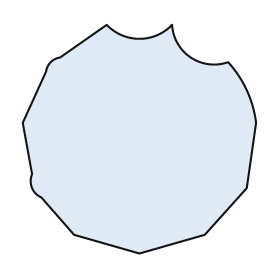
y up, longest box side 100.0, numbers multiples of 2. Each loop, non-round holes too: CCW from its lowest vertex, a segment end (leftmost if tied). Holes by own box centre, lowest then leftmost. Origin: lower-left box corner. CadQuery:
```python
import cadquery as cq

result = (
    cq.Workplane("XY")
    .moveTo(50.0, 0.0)
    .lineTo(78.0, 8.0)
    .lineTo(96.0, 28.0)
    .lineTo(100.0, 56.0)
    .threePointArc((96.0, 70.0), (88.0, 82.0))
    .threePointArc((72.0, 84.0), (64.0, 98.0))
    .threePointArc((50.0, 92.0), (36.0, 98.0))
    .lineTo(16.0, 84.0)
    .threePointArc((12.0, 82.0), (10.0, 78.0))
    .lineTo(0.0, 56.0)
    .lineTo(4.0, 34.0)
    .threePointArc((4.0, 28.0), (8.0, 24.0))
    .lineTo(22.0, 8.0)
    .close()
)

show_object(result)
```